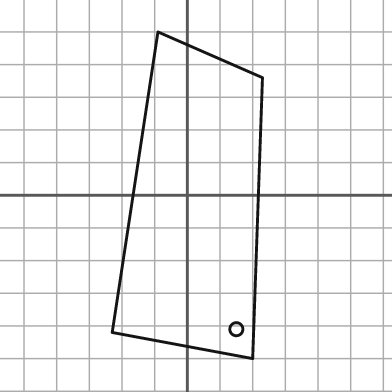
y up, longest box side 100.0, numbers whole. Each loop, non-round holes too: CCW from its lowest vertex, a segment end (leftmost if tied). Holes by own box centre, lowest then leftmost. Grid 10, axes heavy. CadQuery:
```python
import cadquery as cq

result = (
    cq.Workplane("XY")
    .moveTo(20.0, -50.0)
    .lineTo(23.0, 36.0)
    .lineTo(-9.0, 50.0)
    .lineTo(-23.0, -42.0)
    .close()
    .moveTo(15.0, -41.0)
    .circle(2.0)
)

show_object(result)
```